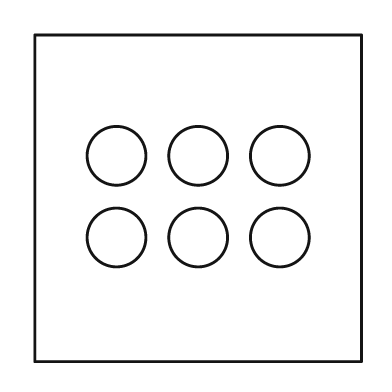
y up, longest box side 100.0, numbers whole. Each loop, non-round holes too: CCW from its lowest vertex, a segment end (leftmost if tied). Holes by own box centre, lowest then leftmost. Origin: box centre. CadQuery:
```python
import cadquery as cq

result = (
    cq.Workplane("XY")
    .moveTo(-50.0, -50.0)
    .lineTo(50.0, -50.0)
    .lineTo(50.0, 50.0)
    .lineTo(-50.0, 50.0)
    .close()
    .moveTo(-25.0, -12.0)
    .circle(9.0)
    .moveTo(0.0, -12.0)
    .circle(9.0)
    .moveTo(25.0, -12.0)
    .circle(9.0)
    .moveTo(-25.0, 13.0)
    .circle(9.0)
    .moveTo(0.0, 13.0)
    .circle(9.0)
    .moveTo(25.0, 13.0)
    .circle(9.0)
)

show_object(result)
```